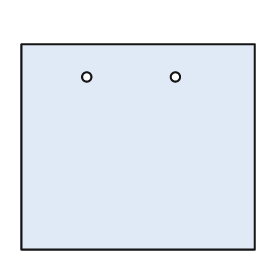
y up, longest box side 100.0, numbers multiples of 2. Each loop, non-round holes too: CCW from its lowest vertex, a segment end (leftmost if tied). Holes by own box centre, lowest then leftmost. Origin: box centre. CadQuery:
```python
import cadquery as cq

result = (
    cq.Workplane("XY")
    .moveTo(-50.0, -44.0)
    .lineTo(50.0, -44.0)
    .lineTo(50.0, 44.0)
    .lineTo(-50.0, 44.0)
    .close()
    .moveTo(-22.0, 30.0)
    .circle(2.0)
    .moveTo(16.0, 30.0)
    .circle(2.0)
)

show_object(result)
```